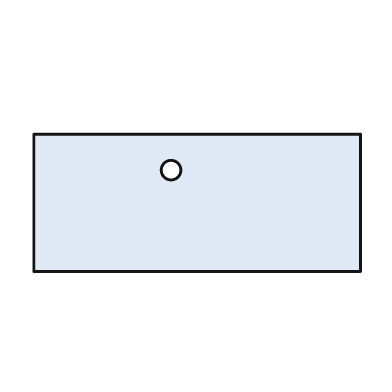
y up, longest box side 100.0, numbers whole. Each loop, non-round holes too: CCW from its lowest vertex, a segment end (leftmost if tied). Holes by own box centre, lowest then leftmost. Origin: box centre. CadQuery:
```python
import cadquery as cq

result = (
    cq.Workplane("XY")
    .moveTo(-50.0, -21.0)
    .lineTo(50.0, -21.0)
    .lineTo(50.0, 21.0)
    .lineTo(-50.0, 21.0)
    .close()
    .moveTo(-8.0, 10.0)
    .circle(3.0)
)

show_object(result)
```